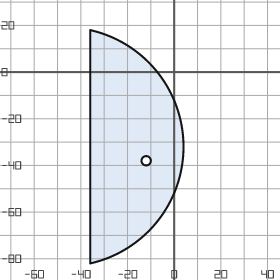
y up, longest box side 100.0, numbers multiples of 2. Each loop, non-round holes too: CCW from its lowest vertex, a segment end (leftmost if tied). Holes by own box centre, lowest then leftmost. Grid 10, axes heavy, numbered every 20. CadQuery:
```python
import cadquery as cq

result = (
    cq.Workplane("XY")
    .moveTo(-36.0, -82.0)
    .threePointArc((4.0, -32.0), (-36.0, 18.0))
    .close()
    .moveTo(-12.0, -38.0)
    .circle(2.0)
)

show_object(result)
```